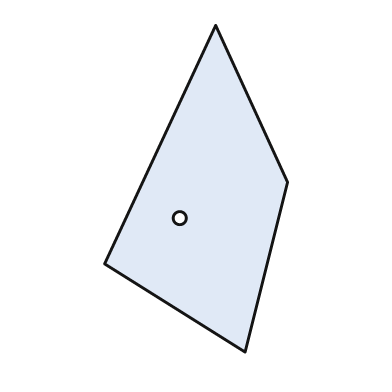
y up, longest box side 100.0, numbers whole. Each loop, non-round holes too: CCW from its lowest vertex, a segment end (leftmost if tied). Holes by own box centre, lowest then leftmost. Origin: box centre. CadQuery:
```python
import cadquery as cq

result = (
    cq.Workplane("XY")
    .moveTo(15.0, -50.0)
    .lineTo(28.0, 2.0)
    .lineTo(6.0, 50.0)
    .lineTo(-28.0, -23.0)
    .close()
    .moveTo(-5.0, -9.0)
    .circle(2.0)
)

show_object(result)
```